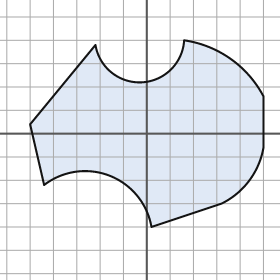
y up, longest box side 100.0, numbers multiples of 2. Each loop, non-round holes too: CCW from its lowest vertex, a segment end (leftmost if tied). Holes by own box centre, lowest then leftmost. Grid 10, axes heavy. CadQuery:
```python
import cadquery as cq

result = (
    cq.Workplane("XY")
    .moveTo(2.0, -40.0)
    .lineTo(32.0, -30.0)
    .threePointArc((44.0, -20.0), (50.0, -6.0))
    .lineTo(50.0, 16.0)
    .threePointArc((36.0, 32.0), (16.0, 40.0))
    .threePointArc((-2.0, 22.0), (-22.0, 38.0))
    .lineTo(-50.0, 4.0)
    .lineTo(-44.0, -22.0)
    .threePointArc((-16.0, -18.0), (2.0, -40.0))
    .close()
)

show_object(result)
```